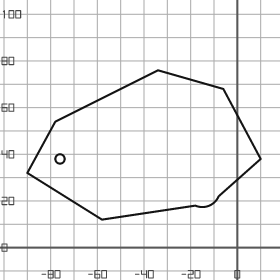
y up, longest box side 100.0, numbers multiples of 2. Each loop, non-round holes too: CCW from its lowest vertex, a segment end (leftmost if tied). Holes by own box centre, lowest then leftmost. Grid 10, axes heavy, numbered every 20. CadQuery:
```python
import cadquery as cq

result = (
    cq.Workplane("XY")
    .moveTo(-58.0, 12.0)
    .lineTo(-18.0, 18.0)
    .threePointArc((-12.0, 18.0), (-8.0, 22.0))
    .lineTo(10.0, 38.0)
    .lineTo(-6.0, 68.0)
    .lineTo(-34.0, 76.0)
    .lineTo(-78.0, 54.0)
    .lineTo(-90.0, 32.0)
    .close()
    .moveTo(-76.0, 38.0)
    .circle(2.0)
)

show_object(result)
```